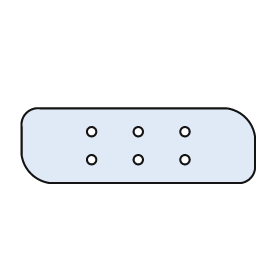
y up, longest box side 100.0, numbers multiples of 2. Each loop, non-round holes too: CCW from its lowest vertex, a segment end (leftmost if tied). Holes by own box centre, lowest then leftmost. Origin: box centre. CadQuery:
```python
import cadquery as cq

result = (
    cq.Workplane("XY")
    .moveTo(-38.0, -16.0)
    .lineTo(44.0, -16.0)
    .threePointArc((48.0, -14.0), (50.0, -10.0))
    .lineTo(50.0, 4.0)
    .threePointArc((46.0, 12.0), (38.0, 16.0))
    .lineTo(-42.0, 16.0)
    .threePointArc((-48.0, 14.0), (-50.0, 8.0))
    .lineTo(-50.0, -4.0)
    .threePointArc((-46.0, -12.0), (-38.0, -16.0))
    .close()
    .moveTo(-20.0, -6.0)
    .circle(2.0)
    .moveTo(0.0, -6.0)
    .circle(2.0)
    .moveTo(20.0, -6.0)
    .circle(2.0)
    .moveTo(-20.0, 6.0)
    .circle(2.0)
    .moveTo(0.0, 6.0)
    .circle(2.0)
    .moveTo(20.0, 6.0)
    .circle(2.0)
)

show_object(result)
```